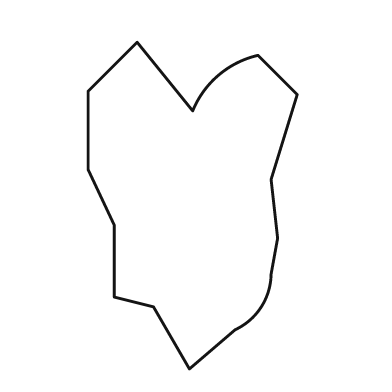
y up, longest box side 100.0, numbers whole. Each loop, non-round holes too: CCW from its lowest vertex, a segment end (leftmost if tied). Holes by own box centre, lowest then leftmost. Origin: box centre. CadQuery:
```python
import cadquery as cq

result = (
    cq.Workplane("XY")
    .moveTo(-1.0, -50.0)
    .lineTo(13.0, -38.0)
    .threePointArc((21.0, -31.0), (24.0, -21.0))
    .lineTo(26.0, -10.0)
    .lineTo(24.0, 8.0)
    .lineTo(32.0, 34.0)
    .lineTo(20.0, 46.0)
    .threePointArc((8.0, 40.0), (0.0, 29.0))
    .lineTo(-17.0, 50.0)
    .lineTo(-32.0, 35.0)
    .lineTo(-32.0, 11.0)
    .lineTo(-24.0, -6.0)
    .lineTo(-24.0, -28.0)
    .lineTo(-12.0, -31.0)
    .close()
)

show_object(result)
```